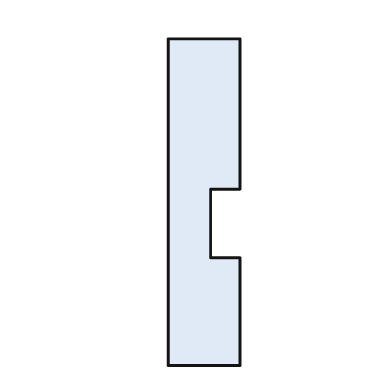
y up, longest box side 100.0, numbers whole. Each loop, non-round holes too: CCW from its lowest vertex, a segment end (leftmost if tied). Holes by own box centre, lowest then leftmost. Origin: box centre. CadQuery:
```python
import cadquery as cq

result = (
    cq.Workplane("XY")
    .moveTo(-11.0, -50.0)
    .lineTo(11.0, -50.0)
    .lineTo(11.0, -17.0)
    .lineTo(2.0, -17.0)
    .lineTo(2.0, 4.0)
    .lineTo(11.0, 4.0)
    .lineTo(11.0, 50.0)
    .lineTo(-11.0, 50.0)
    .close()
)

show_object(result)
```